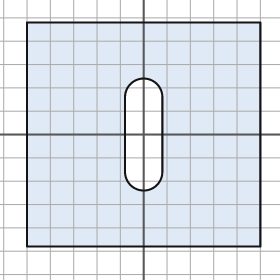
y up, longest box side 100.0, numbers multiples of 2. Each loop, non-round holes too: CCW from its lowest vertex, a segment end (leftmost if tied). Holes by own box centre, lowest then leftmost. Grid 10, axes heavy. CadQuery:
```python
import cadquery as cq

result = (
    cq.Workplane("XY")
    .moveTo(-50.0, -48.0)
    .lineTo(50.0, -48.0)
    .lineTo(50.0, 48.0)
    .lineTo(-50.0, 48.0)
    .close()
    .moveTo(-8.0, -16.0)
    .threePointArc((0.0, -24.0), (8.0, -16.0))
    .lineTo(8.0, 16.0)
    .threePointArc((0.0, 24.0), (-8.0, 16.0))
    .close()
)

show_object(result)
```